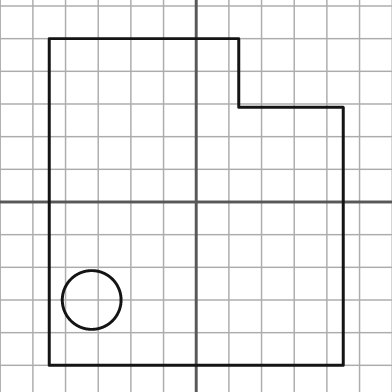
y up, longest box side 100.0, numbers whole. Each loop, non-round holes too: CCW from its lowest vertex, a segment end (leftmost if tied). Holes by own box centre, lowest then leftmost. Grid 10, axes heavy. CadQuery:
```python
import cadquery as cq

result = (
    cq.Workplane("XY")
    .moveTo(-45.0, -50.0)
    .lineTo(45.0, -50.0)
    .lineTo(45.0, 29.0)
    .lineTo(13.0, 29.0)
    .lineTo(13.0, 50.0)
    .lineTo(-45.0, 50.0)
    .close()
    .moveTo(-32.0, -30.0)
    .circle(9.0)
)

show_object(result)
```